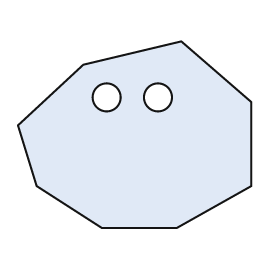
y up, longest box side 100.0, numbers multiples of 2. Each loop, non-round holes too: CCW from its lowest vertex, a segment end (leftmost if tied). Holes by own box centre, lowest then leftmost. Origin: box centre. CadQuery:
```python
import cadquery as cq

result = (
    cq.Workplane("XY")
    .moveTo(-14.0, -40.0)
    .lineTo(18.0, -40.0)
    .lineTo(50.0, -22.0)
    .lineTo(50.0, 14.0)
    .lineTo(20.0, 40.0)
    .lineTo(-22.0, 30.0)
    .lineTo(-50.0, 4.0)
    .lineTo(-42.0, -22.0)
    .close()
    .moveTo(-12.0, 16.0)
    .circle(6.0)
    .moveTo(10.0, 16.0)
    .circle(6.0)
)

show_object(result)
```